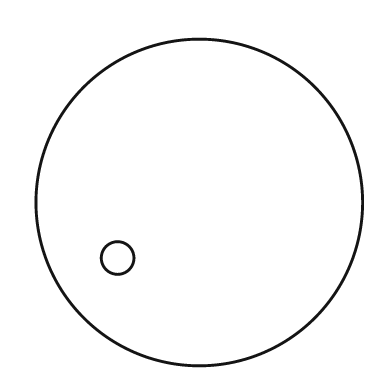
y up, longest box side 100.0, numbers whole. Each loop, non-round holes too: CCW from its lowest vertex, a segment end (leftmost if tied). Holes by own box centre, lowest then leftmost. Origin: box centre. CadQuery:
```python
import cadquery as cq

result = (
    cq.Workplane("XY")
    .moveTo(0.0, 0.0)
    .circle(50.0)
    .moveTo(-25.0, -17.0)
    .circle(5.0)
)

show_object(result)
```